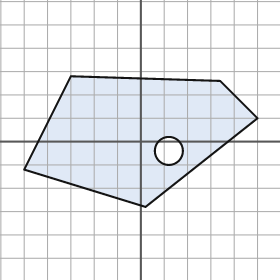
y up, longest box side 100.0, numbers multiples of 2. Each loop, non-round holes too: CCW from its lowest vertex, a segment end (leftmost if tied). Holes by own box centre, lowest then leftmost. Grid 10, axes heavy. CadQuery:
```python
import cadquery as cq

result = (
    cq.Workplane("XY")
    .moveTo(2.0, -28.0)
    .lineTo(50.0, 10.0)
    .lineTo(34.0, 26.0)
    .lineTo(-30.0, 28.0)
    .lineTo(-50.0, -12.0)
    .close()
    .moveTo(12.0, -4.0)
    .circle(6.0)
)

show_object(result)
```